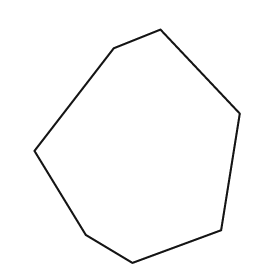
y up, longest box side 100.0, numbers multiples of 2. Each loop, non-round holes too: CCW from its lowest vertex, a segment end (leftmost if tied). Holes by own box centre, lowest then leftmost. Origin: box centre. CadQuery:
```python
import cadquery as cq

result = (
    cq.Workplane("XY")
    .moveTo(-2.0, -50.0)
    .lineTo(36.0, -36.0)
    .lineTo(44.0, 14.0)
    .lineTo(10.0, 50.0)
    .lineTo(-10.0, 42.0)
    .lineTo(-44.0, -2.0)
    .lineTo(-22.0, -38.0)
    .close()
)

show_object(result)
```